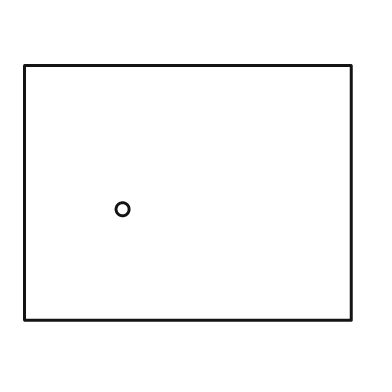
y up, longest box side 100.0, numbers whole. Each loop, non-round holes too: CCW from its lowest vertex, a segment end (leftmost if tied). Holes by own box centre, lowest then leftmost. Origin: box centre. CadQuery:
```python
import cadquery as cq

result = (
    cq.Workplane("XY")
    .moveTo(-50.0, -39.0)
    .lineTo(50.0, -39.0)
    .lineTo(50.0, 39.0)
    .lineTo(-50.0, 39.0)
    .close()
    .moveTo(-20.0, -5.0)
    .circle(2.0)
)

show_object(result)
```